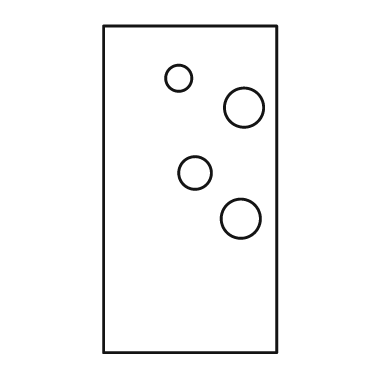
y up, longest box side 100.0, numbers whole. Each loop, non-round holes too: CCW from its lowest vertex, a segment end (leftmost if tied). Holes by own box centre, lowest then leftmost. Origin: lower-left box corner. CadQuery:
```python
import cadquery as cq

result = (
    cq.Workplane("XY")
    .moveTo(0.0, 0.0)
    .lineTo(53.0, 0.0)
    .lineTo(53.0, 100.0)
    .lineTo(0.0, 100.0)
    .close()
    .moveTo(42.0, 41.0)
    .circle(6.0)
    .moveTo(28.0, 55.0)
    .circle(5.0)
    .moveTo(43.0, 75.0)
    .circle(6.0)
    .moveTo(23.0, 84.0)
    .circle(4.0)
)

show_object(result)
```